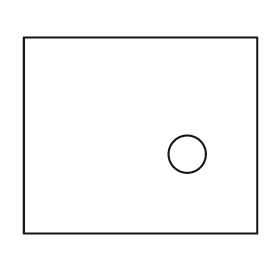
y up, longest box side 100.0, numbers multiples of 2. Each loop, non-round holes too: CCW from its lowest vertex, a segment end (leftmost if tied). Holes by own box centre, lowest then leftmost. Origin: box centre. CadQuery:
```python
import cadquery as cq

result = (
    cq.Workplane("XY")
    .moveTo(-50.0, -42.0)
    .lineTo(50.0, -42.0)
    .lineTo(50.0, 42.0)
    .lineTo(-50.0, 42.0)
    .close()
    .moveTo(20.0, -8.0)
    .circle(8.0)
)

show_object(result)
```